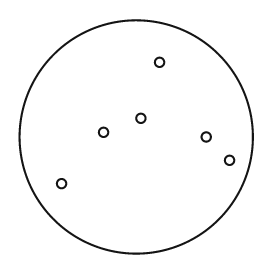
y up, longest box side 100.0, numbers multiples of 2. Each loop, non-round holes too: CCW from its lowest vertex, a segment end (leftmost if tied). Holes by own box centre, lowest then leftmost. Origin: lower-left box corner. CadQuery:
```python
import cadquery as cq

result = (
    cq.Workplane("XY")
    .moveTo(50.0, 50.0)
    .circle(50.0)
    .moveTo(18.0, 30.0)
    .circle(2.0)
    .moveTo(90.0, 40.0)
    .circle(2.0)
    .moveTo(80.0, 50.0)
    .circle(2.0)
    .moveTo(36.0, 52.0)
    .circle(2.0)
    .moveTo(52.0, 58.0)
    .circle(2.0)
    .moveTo(60.0, 82.0)
    .circle(2.0)
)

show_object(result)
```